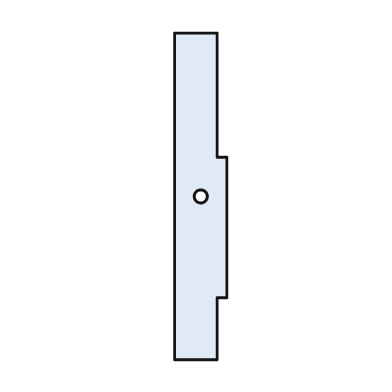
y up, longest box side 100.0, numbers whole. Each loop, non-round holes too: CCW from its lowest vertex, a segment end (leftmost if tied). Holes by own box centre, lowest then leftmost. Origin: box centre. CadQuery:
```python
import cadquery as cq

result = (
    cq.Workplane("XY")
    .moveTo(-8.0, -50.0)
    .lineTo(5.0, -50.0)
    .lineTo(5.0, -31.0)
    .lineTo(8.0, -31.0)
    .lineTo(8.0, 12.0)
    .lineTo(5.0, 12.0)
    .lineTo(5.0, 50.0)
    .lineTo(-8.0, 50.0)
    .close()
    .moveTo(0.0, 0.0)
    .circle(2.0)
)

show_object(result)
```